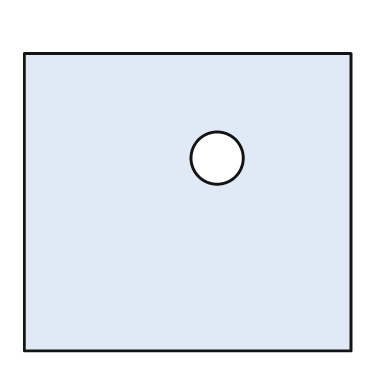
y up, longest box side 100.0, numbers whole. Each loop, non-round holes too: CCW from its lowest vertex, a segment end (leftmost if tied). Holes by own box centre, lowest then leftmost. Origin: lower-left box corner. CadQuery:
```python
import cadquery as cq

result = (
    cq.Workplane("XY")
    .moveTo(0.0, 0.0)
    .lineTo(100.0, 0.0)
    .lineTo(100.0, 91.0)
    .lineTo(0.0, 91.0)
    .close()
    .moveTo(59.0, 59.0)
    .circle(8.0)
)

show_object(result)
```